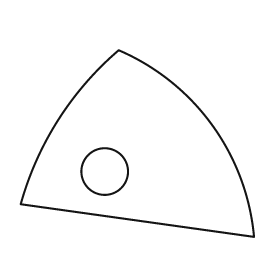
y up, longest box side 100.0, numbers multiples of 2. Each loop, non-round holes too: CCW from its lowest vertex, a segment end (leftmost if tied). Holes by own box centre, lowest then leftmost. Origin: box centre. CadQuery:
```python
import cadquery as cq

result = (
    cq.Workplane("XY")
    .moveTo(50.0, -40.0)
    .threePointArc((32.0, 8.0), (-8.0, 40.0))
    .threePointArc((-34.0, 10.0), (-50.0, -26.0))
    .close()
    .moveTo(-14.0, -12.0)
    .circle(10.0)
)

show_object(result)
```